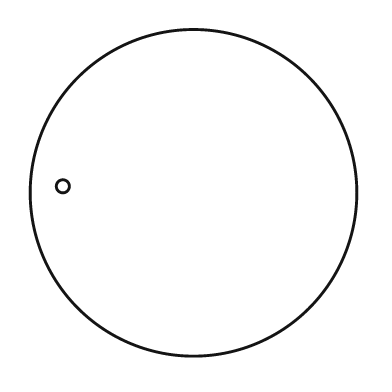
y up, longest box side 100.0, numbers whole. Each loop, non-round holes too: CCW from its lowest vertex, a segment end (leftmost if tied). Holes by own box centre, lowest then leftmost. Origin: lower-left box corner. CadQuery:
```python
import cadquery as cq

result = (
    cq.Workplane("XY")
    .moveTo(50.0, 50.0)
    .circle(50.0)
    .moveTo(10.0, 52.0)
    .circle(2.0)
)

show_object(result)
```